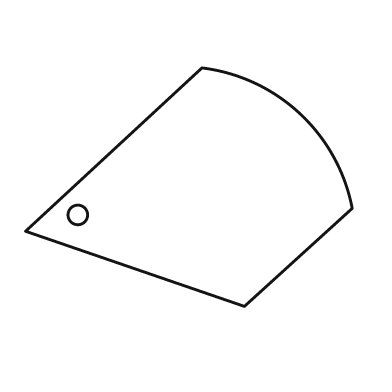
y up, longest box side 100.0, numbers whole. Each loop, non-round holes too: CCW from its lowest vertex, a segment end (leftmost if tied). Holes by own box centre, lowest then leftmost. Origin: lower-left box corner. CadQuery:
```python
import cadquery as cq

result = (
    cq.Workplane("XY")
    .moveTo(67.0, 0.0)
    .lineTo(100.0, 30.0)
    .threePointArc((84.0, 59.0), (54.0, 73.0))
    .lineTo(0.0, 23.0)
    .close()
    .moveTo(16.0, 28.0)
    .circle(3.0)
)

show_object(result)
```